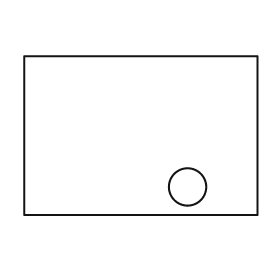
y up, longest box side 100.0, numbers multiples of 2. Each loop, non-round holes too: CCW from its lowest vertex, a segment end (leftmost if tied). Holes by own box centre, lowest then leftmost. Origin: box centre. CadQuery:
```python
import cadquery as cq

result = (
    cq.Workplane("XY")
    .moveTo(-50.0, -34.0)
    .lineTo(50.0, -34.0)
    .lineTo(50.0, 34.0)
    .lineTo(-50.0, 34.0)
    .close()
    .moveTo(20.0, -22.0)
    .circle(8.0)
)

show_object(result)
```